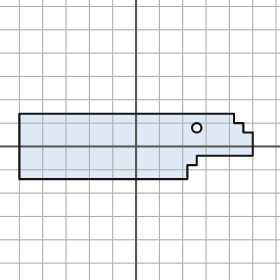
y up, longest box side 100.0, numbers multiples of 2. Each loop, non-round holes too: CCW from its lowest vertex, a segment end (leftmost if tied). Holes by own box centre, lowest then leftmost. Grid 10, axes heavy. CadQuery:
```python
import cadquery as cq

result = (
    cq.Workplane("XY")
    .moveTo(-50.0, -14.0)
    .lineTo(22.0, -14.0)
    .lineTo(22.0, -8.0)
    .lineTo(26.0, -8.0)
    .lineTo(26.0, -4.0)
    .lineTo(50.0, -4.0)
    .lineTo(50.0, 6.0)
    .lineTo(46.0, 6.0)
    .lineTo(46.0, 10.0)
    .lineTo(42.0, 10.0)
    .lineTo(42.0, 14.0)
    .lineTo(-50.0, 14.0)
    .close()
    .moveTo(26.0, 8.0)
    .circle(2.0)
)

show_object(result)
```